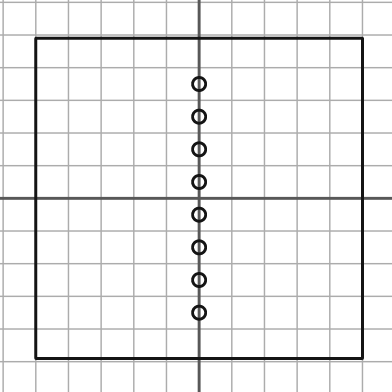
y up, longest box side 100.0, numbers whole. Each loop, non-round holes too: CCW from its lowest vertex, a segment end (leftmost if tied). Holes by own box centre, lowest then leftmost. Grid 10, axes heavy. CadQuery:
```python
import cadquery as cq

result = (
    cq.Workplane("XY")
    .moveTo(-50.0, -49.0)
    .lineTo(50.0, -49.0)
    .lineTo(50.0, 49.0)
    .lineTo(-50.0, 49.0)
    .close()
    .moveTo(0.0, -35.0)
    .circle(2.0)
    .moveTo(0.0, -25.0)
    .circle(2.0)
    .moveTo(0.0, -15.0)
    .circle(2.0)
    .moveTo(0.0, -5.0)
    .circle(2.0)
    .moveTo(0.0, 5.0)
    .circle(2.0)
    .moveTo(0.0, 15.0)
    .circle(2.0)
    .moveTo(0.0, 25.0)
    .circle(2.0)
    .moveTo(0.0, 35.0)
    .circle(2.0)
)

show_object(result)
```